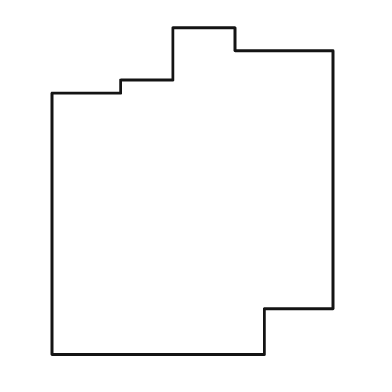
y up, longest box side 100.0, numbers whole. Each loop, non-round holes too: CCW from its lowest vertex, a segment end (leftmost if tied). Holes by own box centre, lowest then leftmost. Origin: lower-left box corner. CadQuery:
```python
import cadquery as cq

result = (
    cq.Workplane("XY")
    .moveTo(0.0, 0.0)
    .lineTo(65.0, 0.0)
    .lineTo(65.0, 14.0)
    .lineTo(86.0, 14.0)
    .lineTo(86.0, 93.0)
    .lineTo(56.0, 93.0)
    .lineTo(56.0, 100.0)
    .lineTo(37.0, 100.0)
    .lineTo(37.0, 84.0)
    .lineTo(21.0, 84.0)
    .lineTo(21.0, 80.0)
    .lineTo(0.0, 80.0)
    .close()
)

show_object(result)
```